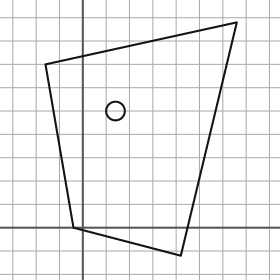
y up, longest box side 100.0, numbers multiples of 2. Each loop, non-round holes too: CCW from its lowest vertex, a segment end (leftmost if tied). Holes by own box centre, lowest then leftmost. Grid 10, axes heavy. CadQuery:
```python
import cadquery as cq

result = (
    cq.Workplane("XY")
    .moveTo(42.0, -12.0)
    .lineTo(66.0, 88.0)
    .lineTo(-16.0, 70.0)
    .lineTo(-4.0, 0.0)
    .close()
    .moveTo(14.0, 50.0)
    .circle(4.0)
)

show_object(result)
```